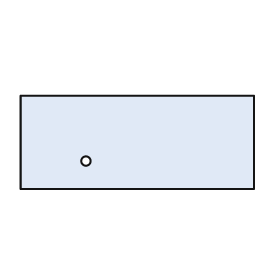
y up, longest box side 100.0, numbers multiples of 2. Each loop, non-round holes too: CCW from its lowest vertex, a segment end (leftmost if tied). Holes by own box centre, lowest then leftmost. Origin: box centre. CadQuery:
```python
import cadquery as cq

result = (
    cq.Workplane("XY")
    .moveTo(-50.0, -20.0)
    .lineTo(50.0, -20.0)
    .lineTo(50.0, 20.0)
    .lineTo(-50.0, 20.0)
    .close()
    .moveTo(-22.0, -8.0)
    .circle(2.0)
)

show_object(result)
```